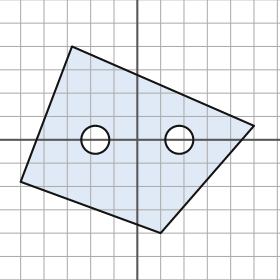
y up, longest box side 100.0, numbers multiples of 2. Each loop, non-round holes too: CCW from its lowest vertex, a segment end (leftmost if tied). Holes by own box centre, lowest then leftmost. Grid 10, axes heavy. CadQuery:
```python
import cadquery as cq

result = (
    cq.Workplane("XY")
    .moveTo(10.0, -40.0)
    .lineTo(50.0, 6.0)
    .lineTo(-28.0, 40.0)
    .lineTo(-50.0, -18.0)
    .close()
    .moveTo(-18.0, 0.0)
    .circle(6.0)
    .moveTo(18.0, 0.0)
    .circle(6.0)
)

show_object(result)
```